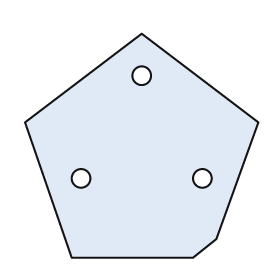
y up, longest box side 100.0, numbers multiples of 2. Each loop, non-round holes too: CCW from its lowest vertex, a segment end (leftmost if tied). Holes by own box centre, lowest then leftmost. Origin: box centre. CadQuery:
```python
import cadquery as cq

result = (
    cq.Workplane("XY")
    .moveTo(-30.0, -48.0)
    .lineTo(22.0, -48.0)
    .lineTo(32.0, -40.0)
    .lineTo(50.0, 10.0)
    .lineTo(0.0, 48.0)
    .lineTo(-50.0, 10.0)
    .close()
    .moveTo(-26.0, -14.0)
    .circle(4.0)
    .moveTo(26.0, -14.0)
    .circle(4.0)
    .moveTo(0.0, 30.0)
    .circle(4.0)
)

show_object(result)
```